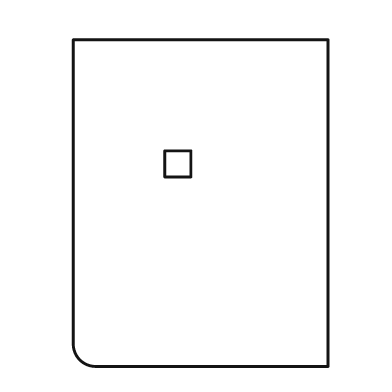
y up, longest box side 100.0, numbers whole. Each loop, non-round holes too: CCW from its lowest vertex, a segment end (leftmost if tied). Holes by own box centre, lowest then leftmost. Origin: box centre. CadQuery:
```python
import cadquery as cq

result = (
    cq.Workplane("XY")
    .moveTo(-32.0, -50.0)
    .lineTo(39.0, -50.0)
    .lineTo(39.0, 50.0)
    .lineTo(-39.0, 50.0)
    .lineTo(-39.0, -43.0)
    .threePointArc((-37.0, -48.0), (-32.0, -50.0))
    .close()
    .moveTo(-11.0, 8.0)
    .lineTo(-3.0, 8.0)
    .lineTo(-3.0, 16.0)
    .lineTo(-11.0, 16.0)
    .close()
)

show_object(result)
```